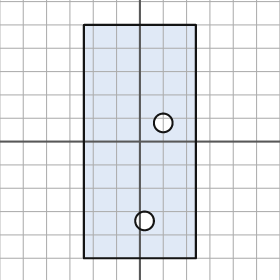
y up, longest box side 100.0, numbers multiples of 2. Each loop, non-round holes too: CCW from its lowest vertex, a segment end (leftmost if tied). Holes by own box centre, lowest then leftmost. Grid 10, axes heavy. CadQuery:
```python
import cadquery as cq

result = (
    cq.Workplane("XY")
    .moveTo(-24.0, -50.0)
    .lineTo(24.0, -50.0)
    .lineTo(24.0, 50.0)
    .lineTo(-24.0, 50.0)
    .close()
    .moveTo(2.0, -34.0)
    .circle(4.0)
    .moveTo(10.0, 8.0)
    .circle(4.0)
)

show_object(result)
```